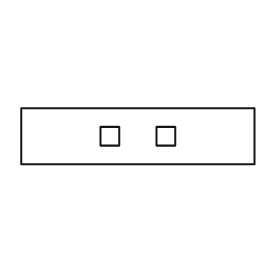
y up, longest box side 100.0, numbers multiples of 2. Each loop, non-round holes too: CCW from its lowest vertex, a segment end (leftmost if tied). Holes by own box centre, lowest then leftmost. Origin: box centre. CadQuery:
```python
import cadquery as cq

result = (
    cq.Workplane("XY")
    .moveTo(-50.0, -12.0)
    .lineTo(50.0, -12.0)
    .lineTo(50.0, 12.0)
    .lineTo(-50.0, 12.0)
    .close()
    .moveTo(-16.0, -4.0)
    .lineTo(-8.0, -4.0)
    .lineTo(-8.0, 4.0)
    .lineTo(-16.0, 4.0)
    .close()
    .moveTo(8.0, -4.0)
    .lineTo(16.0, -4.0)
    .lineTo(16.0, 4.0)
    .lineTo(8.0, 4.0)
    .close()
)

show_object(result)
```